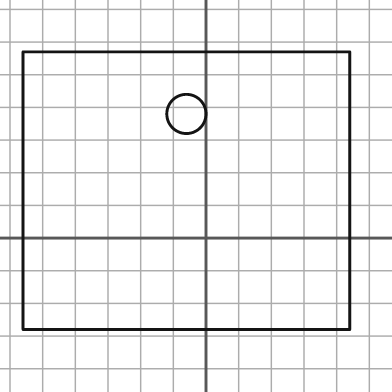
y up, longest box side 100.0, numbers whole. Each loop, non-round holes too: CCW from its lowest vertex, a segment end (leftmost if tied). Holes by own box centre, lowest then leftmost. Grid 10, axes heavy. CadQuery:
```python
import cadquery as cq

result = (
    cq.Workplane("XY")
    .moveTo(-56.0, -28.0)
    .lineTo(44.0, -28.0)
    .lineTo(44.0, 57.0)
    .lineTo(-56.0, 57.0)
    .close()
    .moveTo(-6.0, 38.0)
    .circle(6.0)
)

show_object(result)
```